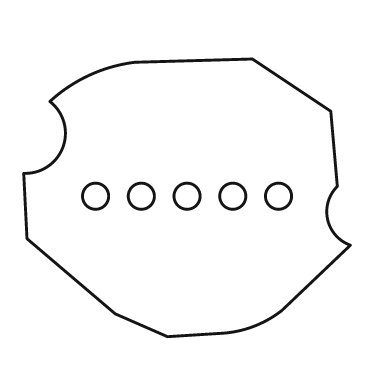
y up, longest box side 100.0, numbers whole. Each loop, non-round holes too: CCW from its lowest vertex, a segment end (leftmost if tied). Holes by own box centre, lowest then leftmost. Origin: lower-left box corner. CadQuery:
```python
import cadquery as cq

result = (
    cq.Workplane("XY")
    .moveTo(44.0, 0.0)
    .lineTo(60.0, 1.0)
    .threePointArc((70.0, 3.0), (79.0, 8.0))
    .lineTo(100.0, 28.0)
    .threePointArc((93.0, 36.0), (96.0, 46.0))
    .lineTo(94.0, 69.0)
    .lineTo(70.0, 85.0)
    .lineTo(34.0, 84.0)
    .threePointArc((20.0, 80.0), (8.0, 72.0))
    .threePointArc((12.0, 58.0), (0.0, 50.0))
    .lineTo(1.0, 30.0)
    .lineTo(28.0, 7.0)
    .close()
    .moveTo(22.0, 43.0)
    .circle(4.0)
    .moveTo(36.0, 43.0)
    .circle(4.0)
    .moveTo(50.0, 43.0)
    .circle(4.0)
    .moveTo(64.0, 43.0)
    .circle(4.0)
    .moveTo(78.0, 43.0)
    .circle(4.0)
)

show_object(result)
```